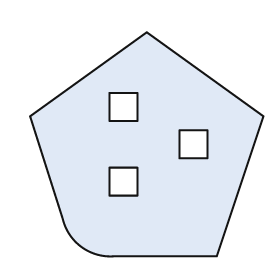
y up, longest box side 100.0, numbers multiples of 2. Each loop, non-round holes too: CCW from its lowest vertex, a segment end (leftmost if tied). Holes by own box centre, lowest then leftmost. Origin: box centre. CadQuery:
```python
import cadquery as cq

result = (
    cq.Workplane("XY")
    .moveTo(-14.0, -48.0)
    .lineTo(30.0, -48.0)
    .lineTo(50.0, 12.0)
    .lineTo(0.0, 48.0)
    .lineTo(-50.0, 12.0)
    .lineTo(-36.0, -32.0)
    .threePointArc((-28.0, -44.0), (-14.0, -48.0))
    .close()
    .moveTo(-16.0, -22.0)
    .lineTo(-4.0, -22.0)
    .lineTo(-4.0, -10.0)
    .lineTo(-16.0, -10.0)
    .close()
    .moveTo(14.0, -6.0)
    .lineTo(26.0, -6.0)
    .lineTo(26.0, 6.0)
    .lineTo(14.0, 6.0)
    .close()
    .moveTo(-16.0, 10.0)
    .lineTo(-4.0, 10.0)
    .lineTo(-4.0, 22.0)
    .lineTo(-16.0, 22.0)
    .close()
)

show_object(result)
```